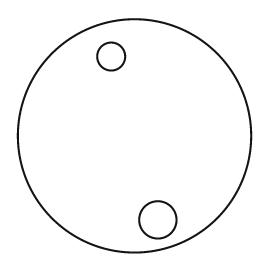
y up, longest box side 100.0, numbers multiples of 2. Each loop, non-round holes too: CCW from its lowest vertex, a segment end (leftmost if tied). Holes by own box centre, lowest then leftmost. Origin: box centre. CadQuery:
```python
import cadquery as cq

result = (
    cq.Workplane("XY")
    .moveTo(0.0, 0.0)
    .circle(50.0)
    .moveTo(10.0, -36.0)
    .circle(8.0)
    .moveTo(-10.0, 34.0)
    .circle(6.0)
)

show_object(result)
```